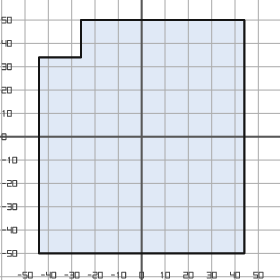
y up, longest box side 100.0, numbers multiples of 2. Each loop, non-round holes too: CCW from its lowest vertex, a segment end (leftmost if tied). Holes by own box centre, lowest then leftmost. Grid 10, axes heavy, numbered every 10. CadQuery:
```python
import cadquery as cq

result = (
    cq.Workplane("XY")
    .moveTo(-44.0, -50.0)
    .lineTo(44.0, -50.0)
    .lineTo(44.0, 50.0)
    .lineTo(-26.0, 50.0)
    .lineTo(-26.0, 34.0)
    .lineTo(-44.0, 34.0)
    .close()
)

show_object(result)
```